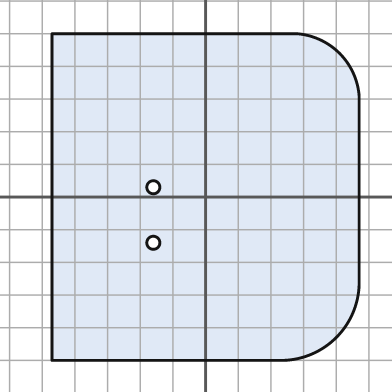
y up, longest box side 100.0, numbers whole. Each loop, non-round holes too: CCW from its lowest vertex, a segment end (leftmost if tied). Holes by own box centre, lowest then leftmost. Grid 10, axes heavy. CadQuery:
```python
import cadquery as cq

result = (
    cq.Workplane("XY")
    .moveTo(-47.0, -50.0)
    .lineTo(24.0, -50.0)
    .threePointArc((40.0, -43.0), (47.0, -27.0))
    .lineTo(47.0, 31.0)
    .threePointArc((41.0, 44.0), (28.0, 50.0))
    .lineTo(-47.0, 50.0)
    .close()
    .moveTo(-16.0, -14.0)
    .circle(2.0)
    .moveTo(-16.0, 3.0)
    .circle(2.0)
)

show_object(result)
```